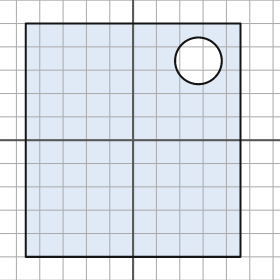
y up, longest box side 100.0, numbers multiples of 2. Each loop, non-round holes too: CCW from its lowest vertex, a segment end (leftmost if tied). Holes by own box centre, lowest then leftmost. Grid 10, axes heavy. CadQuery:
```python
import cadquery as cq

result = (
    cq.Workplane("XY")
    .moveTo(-46.0, -50.0)
    .lineTo(46.0, -50.0)
    .lineTo(46.0, 50.0)
    .lineTo(-46.0, 50.0)
    .close()
    .moveTo(28.0, 34.0)
    .circle(10.0)
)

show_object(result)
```